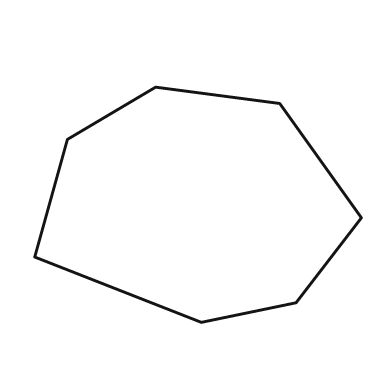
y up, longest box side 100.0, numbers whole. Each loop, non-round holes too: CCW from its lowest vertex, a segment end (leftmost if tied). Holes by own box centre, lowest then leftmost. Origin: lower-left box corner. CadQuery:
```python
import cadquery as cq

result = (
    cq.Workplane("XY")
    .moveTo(51.0, 0.0)
    .lineTo(80.0, 6.0)
    .lineTo(100.0, 32.0)
    .lineTo(75.0, 67.0)
    .lineTo(37.0, 72.0)
    .lineTo(10.0, 56.0)
    .lineTo(0.0, 20.0)
    .close()
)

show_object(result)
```